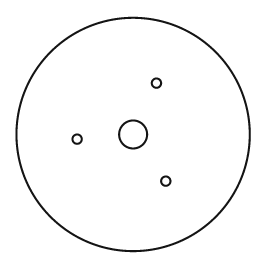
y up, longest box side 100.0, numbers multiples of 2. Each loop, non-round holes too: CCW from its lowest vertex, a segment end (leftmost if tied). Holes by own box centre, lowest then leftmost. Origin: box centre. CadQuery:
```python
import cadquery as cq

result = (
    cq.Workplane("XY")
    .moveTo(0.0, 0.0)
    .circle(50.0)
    .moveTo(14.0, -20.0)
    .circle(2.0)
    .moveTo(-24.0, -2.0)
    .circle(2.0)
    .moveTo(0.0, 0.0)
    .circle(6.0)
    .moveTo(10.0, 22.0)
    .circle(2.0)
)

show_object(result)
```